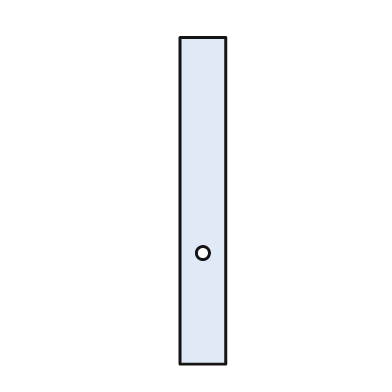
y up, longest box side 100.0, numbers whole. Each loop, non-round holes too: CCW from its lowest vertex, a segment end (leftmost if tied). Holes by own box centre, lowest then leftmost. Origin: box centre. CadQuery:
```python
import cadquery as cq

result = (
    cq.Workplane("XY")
    .moveTo(-7.0, -50.0)
    .lineTo(7.0, -50.0)
    .lineTo(7.0, 50.0)
    .lineTo(-7.0, 50.0)
    .close()
    .moveTo(0.0, -16.0)
    .circle(2.0)
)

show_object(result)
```